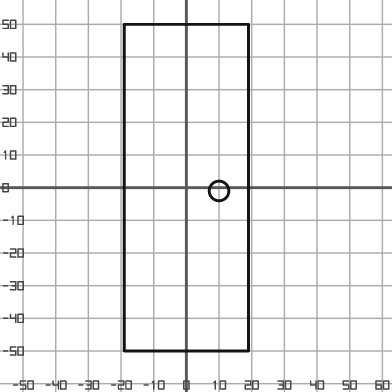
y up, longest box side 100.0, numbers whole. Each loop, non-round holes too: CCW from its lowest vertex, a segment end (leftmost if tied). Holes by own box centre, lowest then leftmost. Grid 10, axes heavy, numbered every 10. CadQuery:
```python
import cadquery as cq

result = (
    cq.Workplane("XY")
    .moveTo(-19.0, -50.0)
    .lineTo(19.0, -50.0)
    .lineTo(19.0, 50.0)
    .lineTo(-19.0, 50.0)
    .close()
    .moveTo(10.0, -1.0)
    .circle(3.0)
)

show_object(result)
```